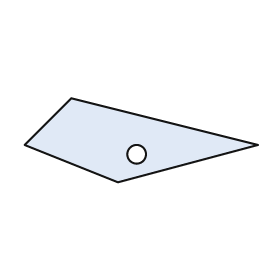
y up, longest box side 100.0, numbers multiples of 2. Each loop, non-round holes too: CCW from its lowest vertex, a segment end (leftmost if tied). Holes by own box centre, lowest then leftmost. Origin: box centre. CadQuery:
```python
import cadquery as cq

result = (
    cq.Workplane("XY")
    .moveTo(-10.0, -18.0)
    .lineTo(50.0, -2.0)
    .lineTo(-30.0, 18.0)
    .lineTo(-50.0, -2.0)
    .close()
    .moveTo(-2.0, -6.0)
    .circle(4.0)
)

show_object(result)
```